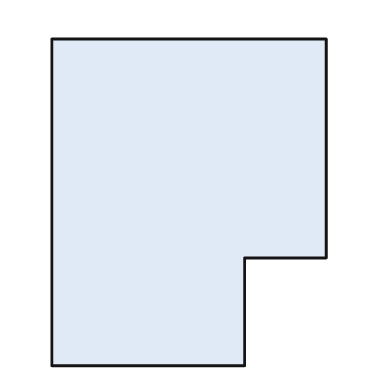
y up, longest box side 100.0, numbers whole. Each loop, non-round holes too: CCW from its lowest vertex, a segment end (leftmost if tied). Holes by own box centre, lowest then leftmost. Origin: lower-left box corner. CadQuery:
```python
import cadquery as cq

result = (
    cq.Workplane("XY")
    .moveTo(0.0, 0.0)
    .lineTo(59.0, 0.0)
    .lineTo(59.0, 33.0)
    .lineTo(84.0, 33.0)
    .lineTo(84.0, 100.0)
    .lineTo(0.0, 100.0)
    .close()
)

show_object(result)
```